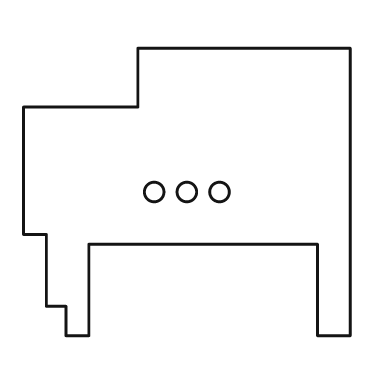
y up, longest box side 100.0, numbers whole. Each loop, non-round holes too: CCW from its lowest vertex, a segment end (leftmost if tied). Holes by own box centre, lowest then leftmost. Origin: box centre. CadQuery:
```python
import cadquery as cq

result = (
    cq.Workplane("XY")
    .moveTo(-37.0, -44.0)
    .lineTo(-30.0, -44.0)
    .lineTo(-30.0, -16.0)
    .lineTo(40.0, -16.0)
    .lineTo(40.0, -44.0)
    .lineTo(50.0, -44.0)
    .lineTo(50.0, 44.0)
    .lineTo(-15.0, 44.0)
    .lineTo(-15.0, 26.0)
    .lineTo(-50.0, 26.0)
    .lineTo(-50.0, -13.0)
    .lineTo(-43.0, -13.0)
    .lineTo(-43.0, -35.0)
    .lineTo(-37.0, -35.0)
    .close()
    .moveTo(-10.0, 0.0)
    .circle(3.0)
    .moveTo(0.0, 0.0)
    .circle(3.0)
    .moveTo(10.0, 0.0)
    .circle(3.0)
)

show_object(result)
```